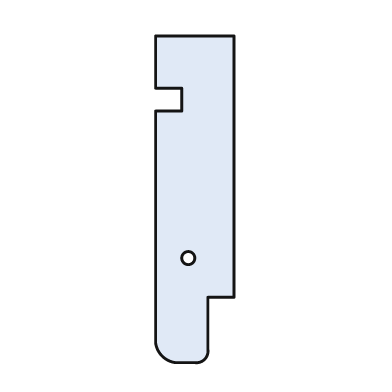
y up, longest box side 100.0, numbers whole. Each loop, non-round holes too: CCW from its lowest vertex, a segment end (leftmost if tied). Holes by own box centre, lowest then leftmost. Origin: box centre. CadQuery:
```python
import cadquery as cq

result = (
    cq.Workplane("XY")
    .moveTo(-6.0, -50.0)
    .lineTo(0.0, -50.0)
    .threePointArc((3.0, -49.0), (4.0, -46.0))
    .lineTo(4.0, -30.0)
    .lineTo(12.0, -30.0)
    .lineTo(12.0, 50.0)
    .lineTo(-12.0, 50.0)
    .lineTo(-12.0, 34.0)
    .lineTo(-4.0, 34.0)
    .lineTo(-4.0, 27.0)
    .lineTo(-12.0, 27.0)
    .lineTo(-12.0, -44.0)
    .threePointArc((-10.0, -48.0), (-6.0, -50.0))
    .close()
    .moveTo(-2.0, -18.0)
    .circle(2.0)
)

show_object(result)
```